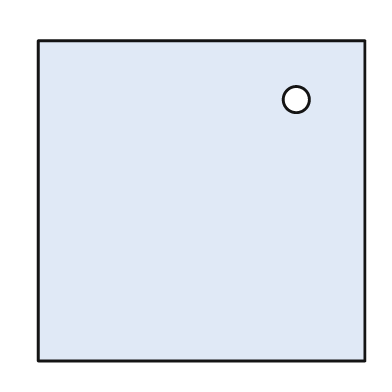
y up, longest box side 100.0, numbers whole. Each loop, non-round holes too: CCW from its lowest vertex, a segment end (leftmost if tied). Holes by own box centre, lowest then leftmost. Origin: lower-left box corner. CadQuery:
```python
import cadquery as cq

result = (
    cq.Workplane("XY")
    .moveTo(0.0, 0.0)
    .lineTo(100.0, 0.0)
    .lineTo(100.0, 98.0)
    .lineTo(0.0, 98.0)
    .close()
    .moveTo(79.0, 80.0)
    .circle(4.0)
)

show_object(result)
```